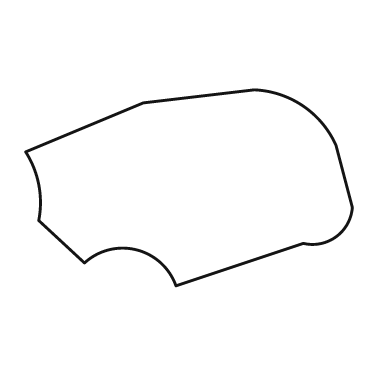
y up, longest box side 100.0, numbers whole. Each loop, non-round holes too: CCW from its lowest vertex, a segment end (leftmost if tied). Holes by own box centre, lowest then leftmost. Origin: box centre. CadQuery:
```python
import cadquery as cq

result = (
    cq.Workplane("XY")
    .moveTo(-4.0, -30.0)
    .lineTo(35.0, -17.0)
    .threePointArc((45.0, -15.0), (50.0, -6.0))
    .lineTo(45.0, 13.0)
    .threePointArc((35.0, 25.0), (20.0, 30.0))
    .lineTo(-14.0, 26.0)
    .lineTo(-50.0, 11.0)
    .threePointArc((-46.0, 1.0), (-46.0, -10.0))
    .lineTo(-32.0, -23.0)
    .threePointArc((-16.0, -19.0), (-4.0, -30.0))
    .close()
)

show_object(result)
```